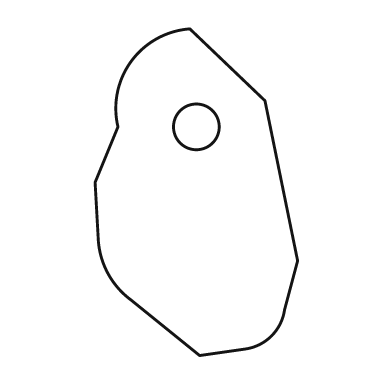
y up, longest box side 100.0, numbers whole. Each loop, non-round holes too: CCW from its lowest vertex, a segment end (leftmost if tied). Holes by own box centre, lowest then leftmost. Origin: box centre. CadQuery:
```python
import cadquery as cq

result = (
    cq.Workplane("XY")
    .moveTo(1.0, -50.0)
    .lineTo(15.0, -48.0)
    .threePointArc((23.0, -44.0), (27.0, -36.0))
    .lineTo(31.0, -21.0)
    .lineTo(21.0, 28.0)
    .lineTo(-2.0, 50.0)
    .threePointArc((-20.0, 40.0), (-24.0, 20.0))
    .lineTo(-31.0, 3.0)
    .lineTo(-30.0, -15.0)
    .threePointArc((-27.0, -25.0), (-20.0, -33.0))
    .close()
    .moveTo(0.0, 20.0)
    .circle(7.0)
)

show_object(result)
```